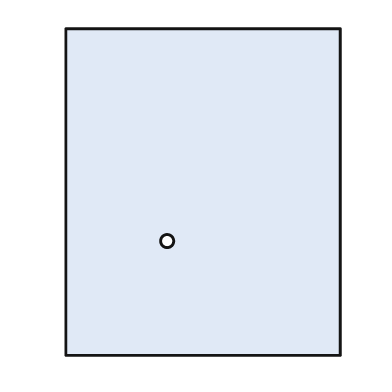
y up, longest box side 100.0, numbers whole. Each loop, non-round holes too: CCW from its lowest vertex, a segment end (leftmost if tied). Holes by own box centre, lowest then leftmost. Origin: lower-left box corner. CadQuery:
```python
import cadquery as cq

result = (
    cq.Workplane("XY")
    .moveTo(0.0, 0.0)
    .lineTo(84.0, 0.0)
    .lineTo(84.0, 100.0)
    .lineTo(0.0, 100.0)
    .close()
    .moveTo(31.0, 35.0)
    .circle(2.0)
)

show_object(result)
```